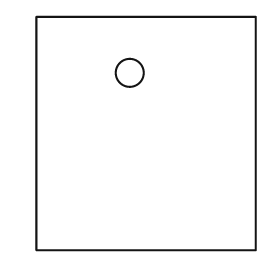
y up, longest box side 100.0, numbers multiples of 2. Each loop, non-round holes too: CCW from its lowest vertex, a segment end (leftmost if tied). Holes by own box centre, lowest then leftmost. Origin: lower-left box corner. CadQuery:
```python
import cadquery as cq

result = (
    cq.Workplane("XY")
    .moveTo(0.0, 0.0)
    .lineTo(94.0, 0.0)
    .lineTo(94.0, 100.0)
    .lineTo(0.0, 100.0)
    .close()
    .moveTo(40.0, 76.0)
    .circle(6.0)
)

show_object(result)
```